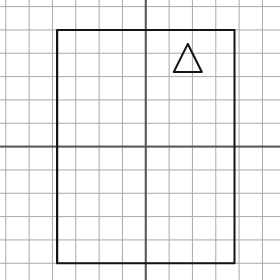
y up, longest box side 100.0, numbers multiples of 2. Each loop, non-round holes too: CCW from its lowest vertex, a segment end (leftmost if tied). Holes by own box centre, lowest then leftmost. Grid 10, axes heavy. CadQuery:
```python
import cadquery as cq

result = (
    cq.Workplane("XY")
    .moveTo(-38.0, -50.0)
    .lineTo(38.0, -50.0)
    .lineTo(38.0, 50.0)
    .lineTo(-38.0, 50.0)
    .close()
    .moveTo(12.0, 32.0)
    .lineTo(24.0, 32.0)
    .lineTo(18.0, 44.0)
    .close()
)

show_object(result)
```